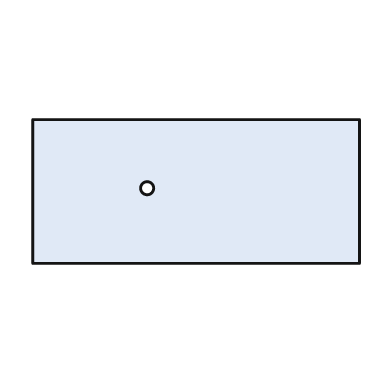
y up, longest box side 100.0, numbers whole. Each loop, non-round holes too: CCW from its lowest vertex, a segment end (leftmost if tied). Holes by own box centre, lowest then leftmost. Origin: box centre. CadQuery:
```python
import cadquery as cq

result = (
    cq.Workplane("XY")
    .moveTo(-50.0, -22.0)
    .lineTo(50.0, -22.0)
    .lineTo(50.0, 22.0)
    .lineTo(-50.0, 22.0)
    .close()
    .moveTo(-15.0, 1.0)
    .circle(2.0)
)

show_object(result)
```